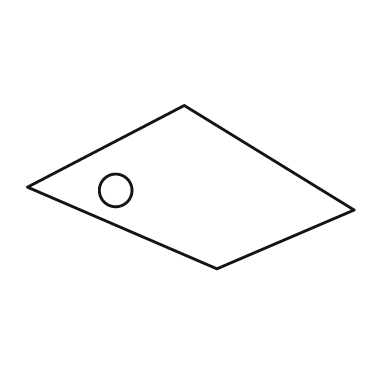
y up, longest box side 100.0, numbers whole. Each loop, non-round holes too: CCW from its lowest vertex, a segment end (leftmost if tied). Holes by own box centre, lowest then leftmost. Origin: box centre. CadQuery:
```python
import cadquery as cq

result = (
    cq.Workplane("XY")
    .moveTo(8.0, -25.0)
    .lineTo(50.0, -7.0)
    .lineTo(-2.0, 25.0)
    .lineTo(-50.0, 0.0)
    .close()
    .moveTo(-23.0, -1.0)
    .circle(5.0)
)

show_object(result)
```